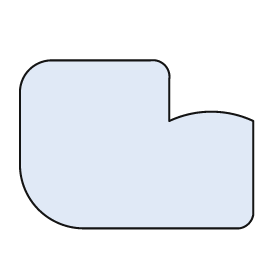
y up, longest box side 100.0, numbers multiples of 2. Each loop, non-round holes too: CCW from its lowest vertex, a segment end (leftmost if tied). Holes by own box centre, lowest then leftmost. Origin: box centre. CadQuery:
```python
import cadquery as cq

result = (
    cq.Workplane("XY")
    .moveTo(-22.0, -36.0)
    .lineTo(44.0, -36.0)
    .threePointArc((48.0, -34.0), (50.0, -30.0))
    .lineTo(50.0, 10.0)
    .threePointArc((32.0, 14.0), (14.0, 10.0))
    .lineTo(14.0, 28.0)
    .threePointArc((12.0, 34.0), (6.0, 36.0))
    .lineTo(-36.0, 36.0)
    .threePointArc((-46.0, 32.0), (-50.0, 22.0))
    .lineTo(-50.0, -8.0)
    .threePointArc((-42.0, -28.0), (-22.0, -36.0))
    .close()
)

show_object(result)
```